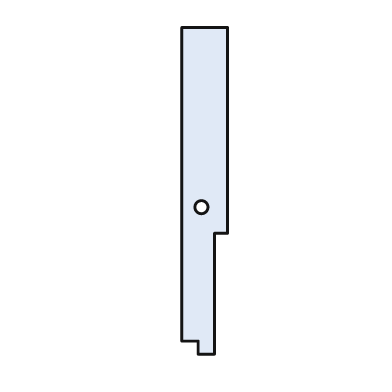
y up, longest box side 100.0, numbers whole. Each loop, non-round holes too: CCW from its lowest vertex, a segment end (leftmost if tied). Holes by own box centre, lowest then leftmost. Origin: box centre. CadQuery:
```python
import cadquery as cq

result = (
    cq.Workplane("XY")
    .moveTo(-2.0, -50.0)
    .lineTo(3.0, -50.0)
    .lineTo(3.0, -13.0)
    .lineTo(7.0, -13.0)
    .lineTo(7.0, 50.0)
    .lineTo(-7.0, 50.0)
    .lineTo(-7.0, -46.0)
    .lineTo(-2.0, -46.0)
    .close()
    .moveTo(-1.0, -5.0)
    .circle(2.0)
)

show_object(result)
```